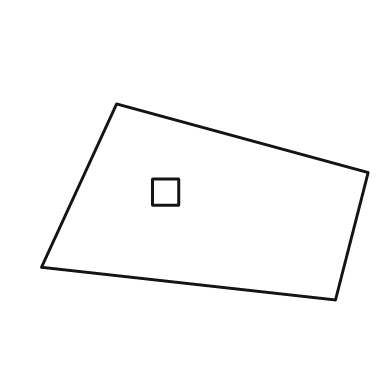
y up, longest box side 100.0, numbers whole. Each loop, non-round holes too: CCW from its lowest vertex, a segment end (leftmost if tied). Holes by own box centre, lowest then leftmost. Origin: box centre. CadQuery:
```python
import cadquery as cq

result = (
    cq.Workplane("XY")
    .moveTo(40.0, -30.0)
    .lineTo(50.0, 9.0)
    .lineTo(-27.0, 30.0)
    .lineTo(-50.0, -20.0)
    .close()
    .moveTo(-16.0, -1.0)
    .lineTo(-8.0, -1.0)
    .lineTo(-8.0, 7.0)
    .lineTo(-16.0, 7.0)
    .close()
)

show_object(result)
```